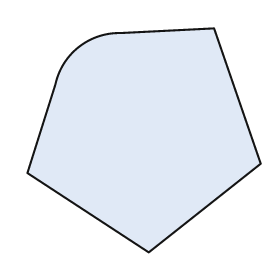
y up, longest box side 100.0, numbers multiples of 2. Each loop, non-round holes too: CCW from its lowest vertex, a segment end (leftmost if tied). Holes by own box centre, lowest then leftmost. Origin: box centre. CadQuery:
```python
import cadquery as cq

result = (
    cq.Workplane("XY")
    .moveTo(2.0, -48.0)
    .lineTo(50.0, -10.0)
    .lineTo(30.0, 48.0)
    .lineTo(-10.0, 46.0)
    .threePointArc((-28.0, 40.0), (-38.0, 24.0))
    .lineTo(-50.0, -14.0)
    .close()
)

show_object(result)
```